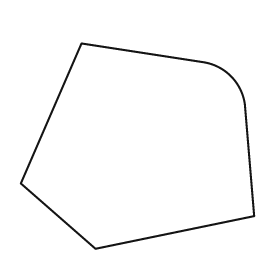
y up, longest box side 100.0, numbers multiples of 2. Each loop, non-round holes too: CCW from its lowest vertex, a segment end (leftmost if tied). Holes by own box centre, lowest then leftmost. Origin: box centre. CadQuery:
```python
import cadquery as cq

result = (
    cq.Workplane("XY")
    .moveTo(-18.0, -44.0)
    .lineTo(50.0, -30.0)
    .lineTo(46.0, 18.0)
    .threePointArc((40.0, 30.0), (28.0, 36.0))
    .lineTo(-24.0, 44.0)
    .lineTo(-50.0, -16.0)
    .close()
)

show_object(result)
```